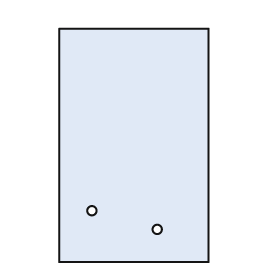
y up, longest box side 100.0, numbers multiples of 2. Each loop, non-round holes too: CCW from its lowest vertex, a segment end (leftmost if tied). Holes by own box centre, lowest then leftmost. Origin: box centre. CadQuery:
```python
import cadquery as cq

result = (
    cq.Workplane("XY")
    .moveTo(-32.0, -50.0)
    .lineTo(32.0, -50.0)
    .lineTo(32.0, 50.0)
    .lineTo(-32.0, 50.0)
    .close()
    .moveTo(10.0, -36.0)
    .circle(2.0)
    .moveTo(-18.0, -28.0)
    .circle(2.0)
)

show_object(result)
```